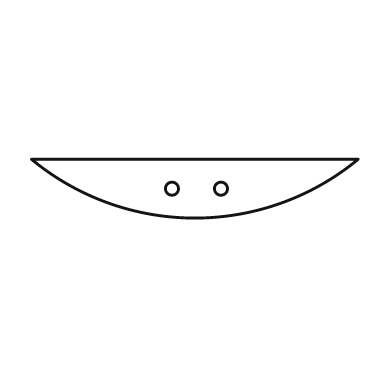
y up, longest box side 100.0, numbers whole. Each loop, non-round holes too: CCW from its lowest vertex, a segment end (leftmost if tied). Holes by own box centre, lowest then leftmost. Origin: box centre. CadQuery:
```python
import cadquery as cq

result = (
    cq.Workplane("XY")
    .moveTo(-50.0, 9.0)
    .threePointArc((0.0, -9.0), (50.0, 9.0))
    .close()
    .moveTo(-7.0, 0.0)
    .circle(2.0)
    .moveTo(8.0, 0.0)
    .circle(2.0)
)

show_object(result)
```